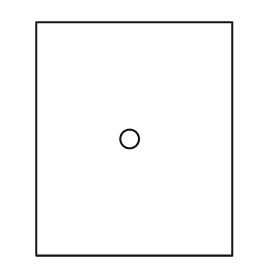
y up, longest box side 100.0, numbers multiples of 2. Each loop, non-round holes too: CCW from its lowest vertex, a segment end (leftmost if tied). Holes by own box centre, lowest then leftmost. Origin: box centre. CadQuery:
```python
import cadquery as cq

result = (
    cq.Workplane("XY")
    .moveTo(-42.0, -50.0)
    .lineTo(42.0, -50.0)
    .lineTo(42.0, 50.0)
    .lineTo(-42.0, 50.0)
    .close()
    .moveTo(-2.0, 0.0)
    .circle(4.0)
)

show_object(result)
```